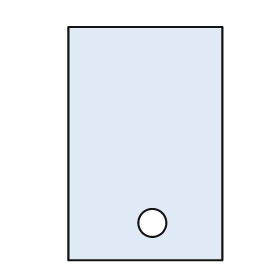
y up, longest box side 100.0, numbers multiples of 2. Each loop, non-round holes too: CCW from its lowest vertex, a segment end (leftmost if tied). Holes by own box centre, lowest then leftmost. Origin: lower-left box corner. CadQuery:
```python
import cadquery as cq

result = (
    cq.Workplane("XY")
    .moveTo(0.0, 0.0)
    .lineTo(66.0, 0.0)
    .lineTo(66.0, 100.0)
    .lineTo(0.0, 100.0)
    .close()
    .moveTo(36.0, 16.0)
    .circle(6.0)
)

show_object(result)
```